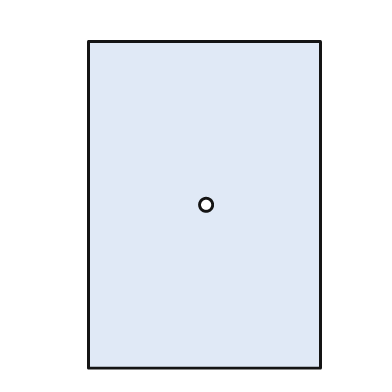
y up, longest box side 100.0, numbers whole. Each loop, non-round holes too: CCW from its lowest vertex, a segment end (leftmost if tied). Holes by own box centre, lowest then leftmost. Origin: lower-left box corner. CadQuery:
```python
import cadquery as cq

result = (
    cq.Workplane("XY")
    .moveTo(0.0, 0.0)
    .lineTo(71.0, 0.0)
    .lineTo(71.0, 100.0)
    .lineTo(0.0, 100.0)
    .close()
    .moveTo(36.0, 50.0)
    .circle(2.0)
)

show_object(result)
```